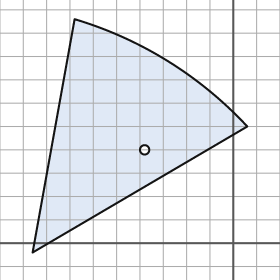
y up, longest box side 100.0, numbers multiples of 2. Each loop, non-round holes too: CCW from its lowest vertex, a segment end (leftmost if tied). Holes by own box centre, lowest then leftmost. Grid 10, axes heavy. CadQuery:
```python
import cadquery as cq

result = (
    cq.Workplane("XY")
    .moveTo(-86.0, -4.0)
    .lineTo(6.0, 50.0)
    .threePointArc((-28.0, 78.0), (-68.0, 96.0))
    .close()
    .moveTo(-38.0, 40.0)
    .circle(2.0)
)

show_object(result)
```